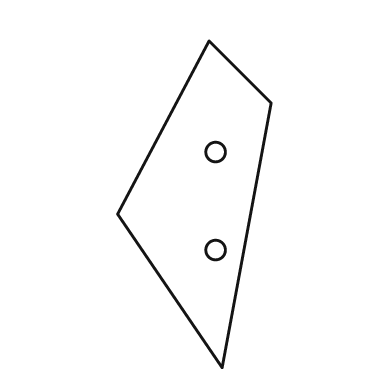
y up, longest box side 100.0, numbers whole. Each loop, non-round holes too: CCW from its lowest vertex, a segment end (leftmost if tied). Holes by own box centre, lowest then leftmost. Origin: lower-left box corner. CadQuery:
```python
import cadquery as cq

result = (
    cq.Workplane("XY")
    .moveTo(32.0, 0.0)
    .lineTo(47.0, 81.0)
    .lineTo(28.0, 100.0)
    .lineTo(0.0, 47.0)
    .close()
    .moveTo(30.0, 36.0)
    .circle(3.0)
    .moveTo(30.0, 66.0)
    .circle(3.0)
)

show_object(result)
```